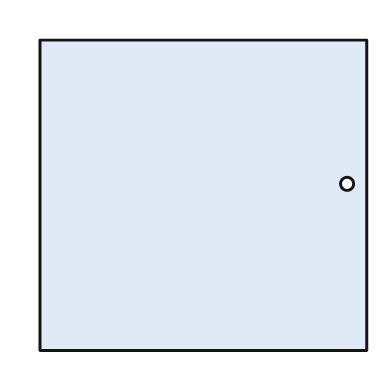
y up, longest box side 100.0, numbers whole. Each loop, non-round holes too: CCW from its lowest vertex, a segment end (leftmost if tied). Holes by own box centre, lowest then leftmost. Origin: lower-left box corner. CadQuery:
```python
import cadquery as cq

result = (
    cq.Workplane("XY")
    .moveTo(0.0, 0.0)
    .lineTo(100.0, 0.0)
    .lineTo(100.0, 95.0)
    .lineTo(0.0, 95.0)
    .close()
    .moveTo(94.0, 51.0)
    .circle(2.0)
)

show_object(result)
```